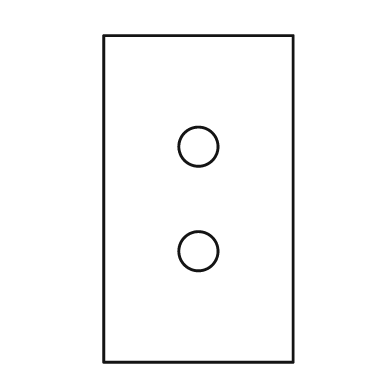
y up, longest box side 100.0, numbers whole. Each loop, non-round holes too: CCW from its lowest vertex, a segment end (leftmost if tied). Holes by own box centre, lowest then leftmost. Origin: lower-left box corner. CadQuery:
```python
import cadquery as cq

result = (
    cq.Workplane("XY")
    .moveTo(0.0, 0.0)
    .lineTo(58.0, 0.0)
    .lineTo(58.0, 100.0)
    .lineTo(0.0, 100.0)
    .close()
    .moveTo(29.0, 34.0)
    .circle(6.0)
    .moveTo(29.0, 66.0)
    .circle(6.0)
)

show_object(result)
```